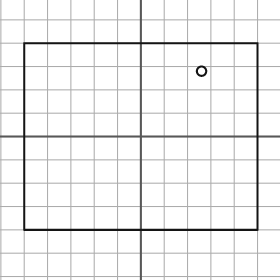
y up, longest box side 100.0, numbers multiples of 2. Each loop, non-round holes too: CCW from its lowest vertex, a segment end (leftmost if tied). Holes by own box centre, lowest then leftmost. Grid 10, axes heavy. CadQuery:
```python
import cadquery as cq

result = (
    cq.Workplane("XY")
    .moveTo(-50.0, -40.0)
    .lineTo(50.0, -40.0)
    .lineTo(50.0, 40.0)
    .lineTo(-50.0, 40.0)
    .close()
    .moveTo(26.0, 28.0)
    .circle(2.0)
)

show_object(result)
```